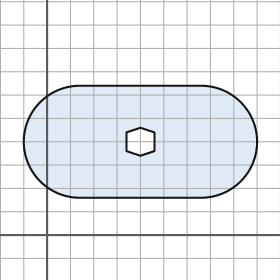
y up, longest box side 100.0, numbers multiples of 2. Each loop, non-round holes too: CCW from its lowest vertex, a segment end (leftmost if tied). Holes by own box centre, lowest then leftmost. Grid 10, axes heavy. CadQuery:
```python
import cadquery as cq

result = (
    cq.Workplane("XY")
    .moveTo(14.0, 16.0)
    .lineTo(66.0, 16.0)
    .threePointArc((90.0, 40.0), (66.0, 64.0))
    .lineTo(14.0, 64.0)
    .threePointArc((-10.0, 40.0), (14.0, 16.0))
    .close()
    .moveTo(40.0, 34.0)
    .lineTo(46.0, 36.0)
    .lineTo(46.0, 44.0)
    .lineTo(40.0, 46.0)
    .lineTo(34.0, 44.0)
    .lineTo(34.0, 36.0)
    .close()
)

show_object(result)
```